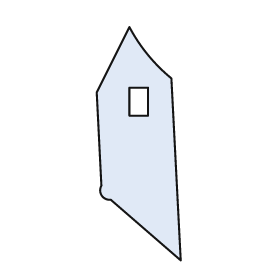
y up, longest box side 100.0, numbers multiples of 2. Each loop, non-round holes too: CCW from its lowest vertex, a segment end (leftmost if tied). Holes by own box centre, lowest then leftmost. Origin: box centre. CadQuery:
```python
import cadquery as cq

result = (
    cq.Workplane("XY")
    .moveTo(18.0, -50.0)
    .lineTo(14.0, 28.0)
    .threePointArc((4.0, 38.0), (-4.0, 50.0))
    .lineTo(-18.0, 22.0)
    .lineTo(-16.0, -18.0)
    .threePointArc((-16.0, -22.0), (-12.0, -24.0))
    .close()
    .moveTo(-4.0, 12.0)
    .lineTo(4.0, 12.0)
    .lineTo(4.0, 24.0)
    .lineTo(-4.0, 24.0)
    .close()
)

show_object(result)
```